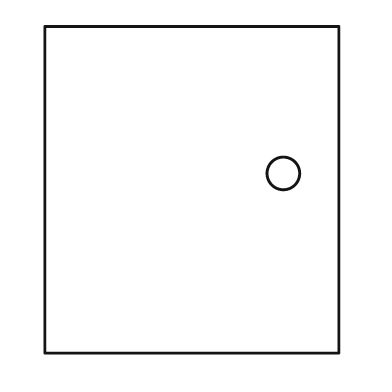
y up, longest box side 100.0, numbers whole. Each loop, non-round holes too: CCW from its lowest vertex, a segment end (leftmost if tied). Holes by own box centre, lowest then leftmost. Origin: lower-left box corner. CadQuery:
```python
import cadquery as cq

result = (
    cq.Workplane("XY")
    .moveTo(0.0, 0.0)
    .lineTo(90.0, 0.0)
    .lineTo(90.0, 100.0)
    .lineTo(0.0, 100.0)
    .close()
    .moveTo(73.0, 55.0)
    .circle(5.0)
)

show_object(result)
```